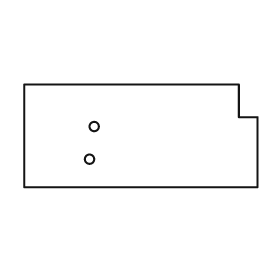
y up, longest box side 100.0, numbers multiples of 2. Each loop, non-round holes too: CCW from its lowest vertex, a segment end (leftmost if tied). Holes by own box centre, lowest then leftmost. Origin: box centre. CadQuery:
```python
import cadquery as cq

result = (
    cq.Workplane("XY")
    .moveTo(-50.0, -22.0)
    .lineTo(50.0, -22.0)
    .lineTo(50.0, 8.0)
    .lineTo(42.0, 8.0)
    .lineTo(42.0, 22.0)
    .lineTo(-50.0, 22.0)
    .close()
    .moveTo(-22.0, -10.0)
    .circle(2.0)
    .moveTo(-20.0, 4.0)
    .circle(2.0)
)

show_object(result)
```